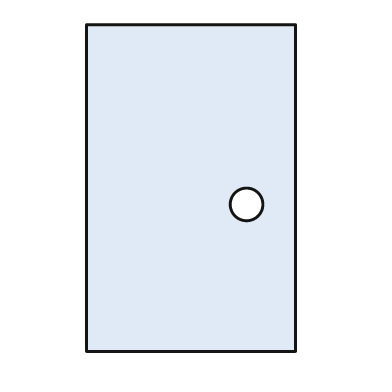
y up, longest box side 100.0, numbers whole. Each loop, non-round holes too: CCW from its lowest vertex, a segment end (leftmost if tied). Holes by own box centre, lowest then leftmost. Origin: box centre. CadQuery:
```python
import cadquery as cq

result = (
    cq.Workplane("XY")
    .moveTo(-32.0, -50.0)
    .lineTo(32.0, -50.0)
    .lineTo(32.0, 50.0)
    .lineTo(-32.0, 50.0)
    .close()
    .moveTo(17.0, -5.0)
    .circle(5.0)
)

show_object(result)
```